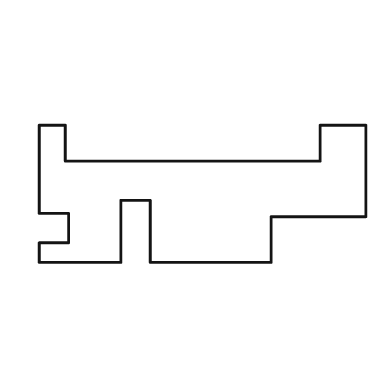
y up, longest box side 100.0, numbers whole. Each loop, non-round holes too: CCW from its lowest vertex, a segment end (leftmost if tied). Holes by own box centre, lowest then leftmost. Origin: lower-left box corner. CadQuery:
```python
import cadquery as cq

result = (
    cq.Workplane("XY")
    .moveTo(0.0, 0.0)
    .lineTo(25.0, 0.0)
    .lineTo(25.0, 19.0)
    .lineTo(34.0, 19.0)
    .lineTo(34.0, 0.0)
    .lineTo(71.0, 0.0)
    .lineTo(71.0, 14.0)
    .lineTo(100.0, 14.0)
    .lineTo(100.0, 42.0)
    .lineTo(86.0, 42.0)
    .lineTo(86.0, 31.0)
    .lineTo(8.0, 31.0)
    .lineTo(8.0, 42.0)
    .lineTo(0.0, 42.0)
    .lineTo(0.0, 15.0)
    .lineTo(9.0, 15.0)
    .lineTo(9.0, 6.0)
    .lineTo(0.0, 6.0)
    .close()
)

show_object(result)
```